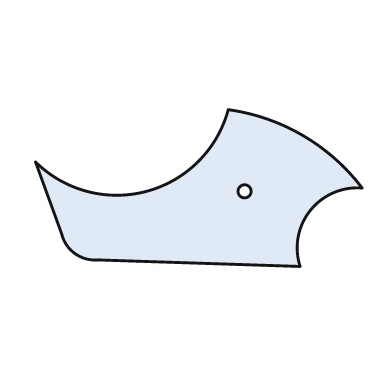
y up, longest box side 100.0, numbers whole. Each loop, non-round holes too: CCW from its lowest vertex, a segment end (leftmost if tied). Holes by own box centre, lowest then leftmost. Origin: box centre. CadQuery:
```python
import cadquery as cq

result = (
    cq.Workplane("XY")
    .moveTo(31.0, -24.0)
    .threePointArc((34.0, -7.0), (50.0, 0.0))
    .threePointArc((32.0, 16.0), (9.0, 24.0))
    .threePointArc((-16.0, -1.0), (-50.0, 8.0))
    .lineTo(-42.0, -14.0)
    .threePointArc((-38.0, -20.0), (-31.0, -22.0))
    .close()
    .moveTo(14.0, -1.0)
    .circle(2.0)
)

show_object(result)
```